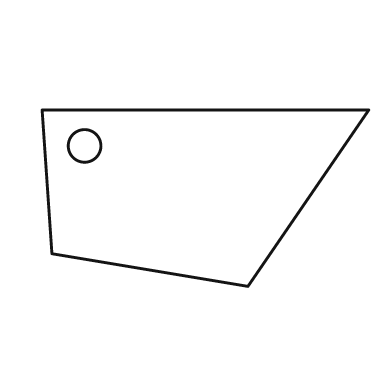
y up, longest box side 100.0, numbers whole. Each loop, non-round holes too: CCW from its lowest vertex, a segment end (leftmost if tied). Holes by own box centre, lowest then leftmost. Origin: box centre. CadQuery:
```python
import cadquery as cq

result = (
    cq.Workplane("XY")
    .moveTo(13.0, -27.0)
    .lineTo(50.0, 27.0)
    .lineTo(-50.0, 27.0)
    .lineTo(-47.0, -17.0)
    .close()
    .moveTo(-37.0, 16.0)
    .circle(5.0)
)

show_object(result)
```